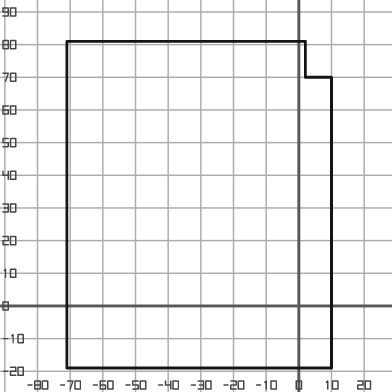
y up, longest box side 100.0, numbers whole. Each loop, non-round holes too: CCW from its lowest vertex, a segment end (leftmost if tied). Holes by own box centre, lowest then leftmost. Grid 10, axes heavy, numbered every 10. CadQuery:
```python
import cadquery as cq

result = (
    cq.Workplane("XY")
    .moveTo(-71.0, -19.0)
    .lineTo(10.0, -19.0)
    .lineTo(10.0, 70.0)
    .lineTo(2.0, 70.0)
    .lineTo(2.0, 81.0)
    .lineTo(-71.0, 81.0)
    .close()
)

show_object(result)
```